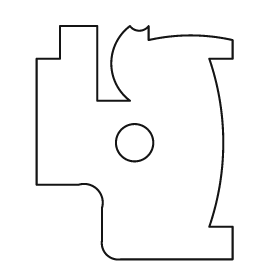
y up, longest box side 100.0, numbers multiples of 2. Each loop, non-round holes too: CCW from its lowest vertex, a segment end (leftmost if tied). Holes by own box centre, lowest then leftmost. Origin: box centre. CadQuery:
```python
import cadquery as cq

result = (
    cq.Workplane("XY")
    .moveTo(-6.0, -50.0)
    .lineTo(42.0, -50.0)
    .lineTo(42.0, -36.0)
    .lineTo(32.0, -36.0)
    .threePointArc((38.0, 0.0), (32.0, 36.0))
    .lineTo(42.0, 36.0)
    .lineTo(42.0, 44.0)
    .threePointArc((24.0, 46.0), (6.0, 44.0))
    .lineTo(6.0, 50.0)
    .threePointArc((2.0, 48.0), (-2.0, 50.0))
    .threePointArc((-10.0, 34.0), (-2.0, 18.0))
    .lineTo(-16.0, 18.0)
    .lineTo(-16.0, 50.0)
    .lineTo(-32.0, 50.0)
    .lineTo(-32.0, 36.0)
    .lineTo(-42.0, 36.0)
    .lineTo(-42.0, -18.0)
    .lineTo(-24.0, -18.0)
    .threePointArc((-16.0, -20.0), (-14.0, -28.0))
    .lineTo(-14.0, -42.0)
    .threePointArc((-12.0, -48.0), (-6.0, -50.0))
    .close()
    .moveTo(0.0, 0.0)
    .circle(8.0)
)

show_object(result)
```